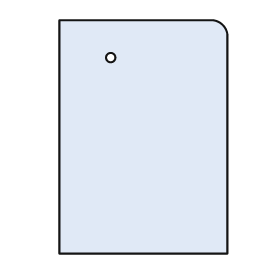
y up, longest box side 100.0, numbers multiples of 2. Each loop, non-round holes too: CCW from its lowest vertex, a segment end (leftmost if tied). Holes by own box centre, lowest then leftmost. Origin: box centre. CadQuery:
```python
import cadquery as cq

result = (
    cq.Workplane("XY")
    .moveTo(-36.0, -50.0)
    .lineTo(36.0, -50.0)
    .lineTo(36.0, 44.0)
    .threePointArc((34.0, 48.0), (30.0, 50.0))
    .lineTo(-36.0, 50.0)
    .close()
    .moveTo(-14.0, 34.0)
    .circle(2.0)
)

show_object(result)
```